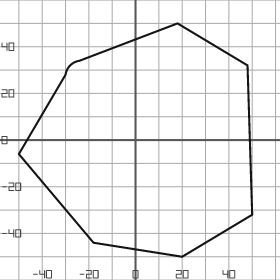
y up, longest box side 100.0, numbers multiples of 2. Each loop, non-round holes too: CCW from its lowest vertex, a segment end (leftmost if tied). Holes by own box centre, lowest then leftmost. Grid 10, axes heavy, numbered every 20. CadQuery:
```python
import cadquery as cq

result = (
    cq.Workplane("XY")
    .moveTo(20.0, -50.0)
    .lineTo(50.0, -32.0)
    .lineTo(48.0, 32.0)
    .lineTo(18.0, 50.0)
    .lineTo(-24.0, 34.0)
    .threePointArc((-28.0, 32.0), (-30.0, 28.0))
    .lineTo(-50.0, -6.0)
    .lineTo(-18.0, -44.0)
    .close()
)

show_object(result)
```